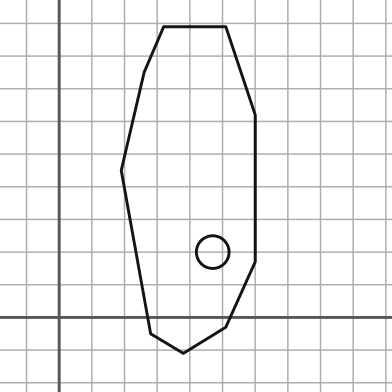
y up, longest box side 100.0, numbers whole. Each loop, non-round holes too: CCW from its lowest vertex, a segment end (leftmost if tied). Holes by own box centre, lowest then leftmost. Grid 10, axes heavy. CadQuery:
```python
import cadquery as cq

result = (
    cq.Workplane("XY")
    .moveTo(38.0, -11.0)
    .lineTo(51.0, -3.0)
    .lineTo(60.0, 17.0)
    .lineTo(60.0, 62.0)
    .lineTo(51.0, 89.0)
    .lineTo(32.0, 89.0)
    .lineTo(26.0, 75.0)
    .lineTo(19.0, 45.0)
    .lineTo(28.0, -5.0)
    .close()
    .moveTo(47.0, 20.0)
    .circle(5.0)
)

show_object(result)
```